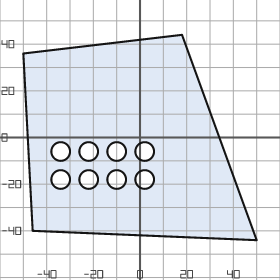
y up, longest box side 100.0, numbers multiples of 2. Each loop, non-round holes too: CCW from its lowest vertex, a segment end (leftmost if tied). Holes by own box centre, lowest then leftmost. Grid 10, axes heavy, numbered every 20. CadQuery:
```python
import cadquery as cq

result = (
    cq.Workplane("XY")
    .moveTo(50.0, -44.0)
    .lineTo(18.0, 44.0)
    .lineTo(-50.0, 36.0)
    .lineTo(-46.0, -40.0)
    .close()
    .moveTo(-34.0, -18.0)
    .circle(4.0)
    .moveTo(-22.0, -18.0)
    .circle(4.0)
    .moveTo(-10.0, -18.0)
    .circle(4.0)
    .moveTo(2.0, -18.0)
    .circle(4.0)
    .moveTo(-34.0, -6.0)
    .circle(4.0)
    .moveTo(-22.0, -6.0)
    .circle(4.0)
    .moveTo(-10.0, -6.0)
    .circle(4.0)
    .moveTo(2.0, -6.0)
    .circle(4.0)
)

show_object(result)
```